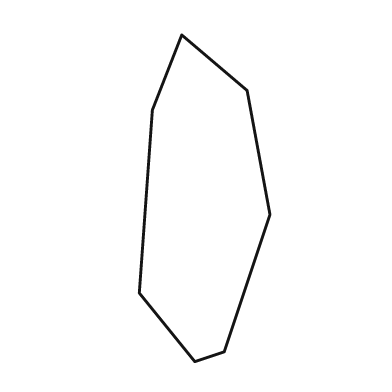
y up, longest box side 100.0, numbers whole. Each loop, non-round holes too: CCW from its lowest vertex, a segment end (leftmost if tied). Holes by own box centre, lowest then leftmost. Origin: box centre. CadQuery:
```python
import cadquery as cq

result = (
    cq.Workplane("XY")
    .moveTo(-3.0, -50.0)
    .lineTo(6.0, -47.0)
    .lineTo(20.0, -5.0)
    .lineTo(13.0, 33.0)
    .lineTo(-7.0, 50.0)
    .lineTo(-16.0, 27.0)
    .lineTo(-20.0, -29.0)
    .close()
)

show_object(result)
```